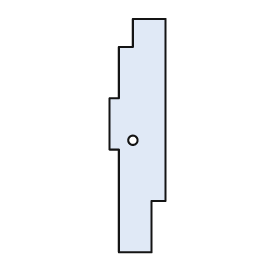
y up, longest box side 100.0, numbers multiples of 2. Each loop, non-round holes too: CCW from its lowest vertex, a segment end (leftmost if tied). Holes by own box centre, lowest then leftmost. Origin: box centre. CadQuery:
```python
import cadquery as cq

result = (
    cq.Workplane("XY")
    .moveTo(-8.0, -50.0)
    .lineTo(6.0, -50.0)
    .lineTo(6.0, -28.0)
    .lineTo(12.0, -28.0)
    .lineTo(12.0, 50.0)
    .lineTo(-2.0, 50.0)
    .lineTo(-2.0, 38.0)
    .lineTo(-8.0, 38.0)
    .lineTo(-8.0, 16.0)
    .lineTo(-12.0, 16.0)
    .lineTo(-12.0, -6.0)
    .lineTo(-8.0, -6.0)
    .close()
    .moveTo(-2.0, -2.0)
    .circle(2.0)
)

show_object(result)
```